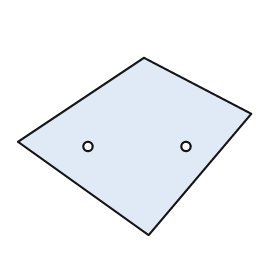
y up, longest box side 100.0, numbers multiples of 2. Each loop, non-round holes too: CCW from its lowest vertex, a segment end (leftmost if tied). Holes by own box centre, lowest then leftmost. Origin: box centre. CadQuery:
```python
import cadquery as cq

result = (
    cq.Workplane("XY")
    .moveTo(6.0, -38.0)
    .lineTo(50.0, 14.0)
    .lineTo(4.0, 38.0)
    .lineTo(-50.0, 2.0)
    .close()
    .moveTo(-20.0, 0.0)
    .circle(2.0)
    .moveTo(22.0, 0.0)
    .circle(2.0)
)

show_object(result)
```